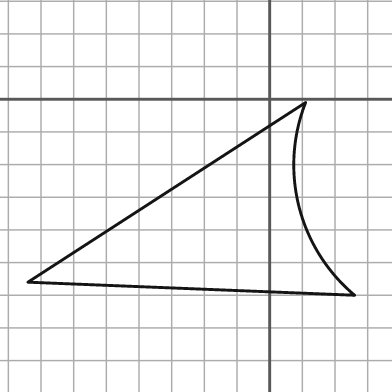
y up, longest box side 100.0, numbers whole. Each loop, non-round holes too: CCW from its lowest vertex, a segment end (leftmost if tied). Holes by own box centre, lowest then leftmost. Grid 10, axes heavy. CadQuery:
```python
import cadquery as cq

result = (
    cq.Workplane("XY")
    .moveTo(26.0, -60.0)
    .threePointArc((9.0, -33.0), (11.0, -1.0))
    .lineTo(-74.0, -56.0)
    .close()
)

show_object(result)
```